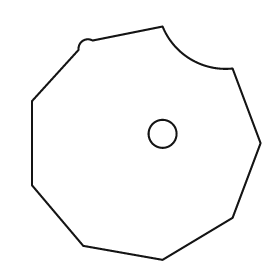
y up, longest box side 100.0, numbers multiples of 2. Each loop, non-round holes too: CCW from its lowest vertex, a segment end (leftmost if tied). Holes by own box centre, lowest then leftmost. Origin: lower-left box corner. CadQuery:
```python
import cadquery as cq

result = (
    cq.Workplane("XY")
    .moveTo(56.0, 0.0)
    .lineTo(86.0, 18.0)
    .lineTo(98.0, 50.0)
    .lineTo(86.0, 82.0)
    .threePointArc((68.0, 86.0), (56.0, 100.0))
    .lineTo(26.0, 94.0)
    .threePointArc((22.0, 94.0), (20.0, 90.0))
    .lineTo(0.0, 68.0)
    .lineTo(0.0, 32.0)
    .lineTo(22.0, 6.0)
    .close()
    .moveTo(56.0, 54.0)
    .circle(6.0)
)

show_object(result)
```